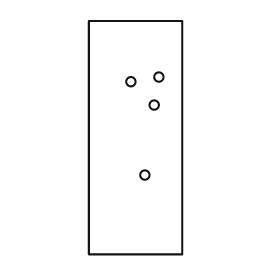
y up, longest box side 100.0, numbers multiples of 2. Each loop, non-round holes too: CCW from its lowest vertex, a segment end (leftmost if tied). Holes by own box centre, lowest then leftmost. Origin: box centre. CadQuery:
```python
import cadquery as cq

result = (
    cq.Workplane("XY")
    .moveTo(-20.0, -50.0)
    .lineTo(20.0, -50.0)
    .lineTo(20.0, 50.0)
    .lineTo(-20.0, 50.0)
    .close()
    .moveTo(4.0, -16.0)
    .circle(2.0)
    .moveTo(8.0, 14.0)
    .circle(2.0)
    .moveTo(-2.0, 24.0)
    .circle(2.0)
    .moveTo(10.0, 26.0)
    .circle(2.0)
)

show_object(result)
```